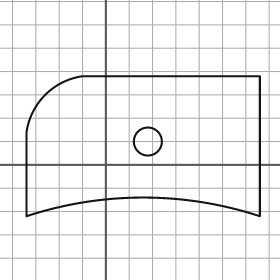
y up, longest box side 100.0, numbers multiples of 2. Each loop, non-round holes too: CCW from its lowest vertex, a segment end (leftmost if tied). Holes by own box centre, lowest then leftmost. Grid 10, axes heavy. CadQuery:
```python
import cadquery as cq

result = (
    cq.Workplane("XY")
    .moveTo(-34.0, -22.0)
    .threePointArc((16.0, -14.0), (66.0, -22.0))
    .lineTo(66.0, 38.0)
    .lineTo(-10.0, 38.0)
    .threePointArc((-26.0, 30.0), (-34.0, 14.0))
    .close()
    .moveTo(18.0, 10.0)
    .circle(6.0)
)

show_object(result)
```